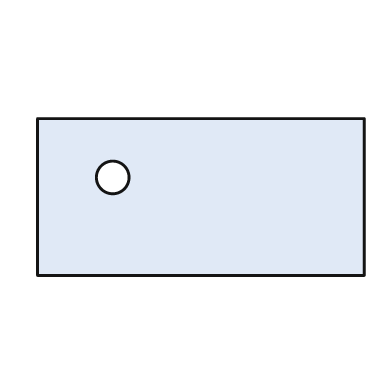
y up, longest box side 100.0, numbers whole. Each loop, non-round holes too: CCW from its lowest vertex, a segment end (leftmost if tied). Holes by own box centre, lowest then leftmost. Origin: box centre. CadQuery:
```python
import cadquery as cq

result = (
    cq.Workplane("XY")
    .moveTo(-50.0, -24.0)
    .lineTo(50.0, -24.0)
    .lineTo(50.0, 24.0)
    .lineTo(-50.0, 24.0)
    .close()
    .moveTo(-27.0, 6.0)
    .circle(5.0)
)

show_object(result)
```